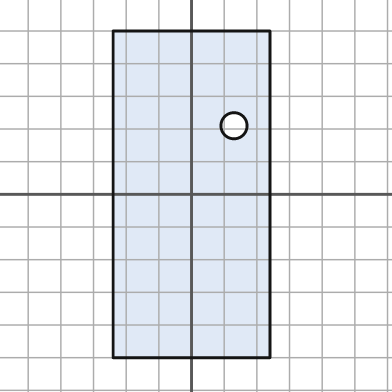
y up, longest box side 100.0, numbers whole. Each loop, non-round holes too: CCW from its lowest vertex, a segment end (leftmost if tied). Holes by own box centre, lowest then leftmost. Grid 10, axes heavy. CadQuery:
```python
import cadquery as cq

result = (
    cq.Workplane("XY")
    .moveTo(-24.0, -50.0)
    .lineTo(24.0, -50.0)
    .lineTo(24.0, 50.0)
    .lineTo(-24.0, 50.0)
    .close()
    .moveTo(13.0, 21.0)
    .circle(4.0)
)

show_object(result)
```